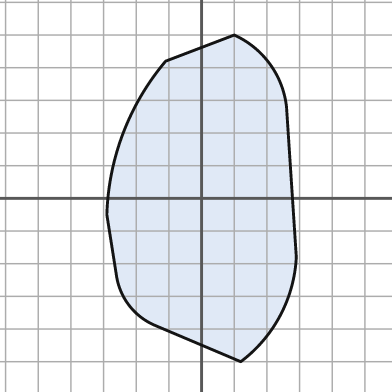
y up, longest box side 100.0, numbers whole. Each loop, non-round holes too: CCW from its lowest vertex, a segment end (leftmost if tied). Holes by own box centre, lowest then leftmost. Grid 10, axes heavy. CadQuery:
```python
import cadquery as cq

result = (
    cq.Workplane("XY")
    .moveTo(12.0, -50.0)
    .threePointArc((24.0, -36.0), (29.0, -18.0))
    .lineTo(26.0, 28.0)
    .threePointArc((21.0, 41.0), (10.0, 50.0))
    .lineTo(-11.0, 42.0)
    .threePointArc((-24.0, 20.0), (-29.0, -5.0))
    .lineTo(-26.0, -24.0)
    .threePointArc((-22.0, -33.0), (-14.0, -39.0))
    .close()
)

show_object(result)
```